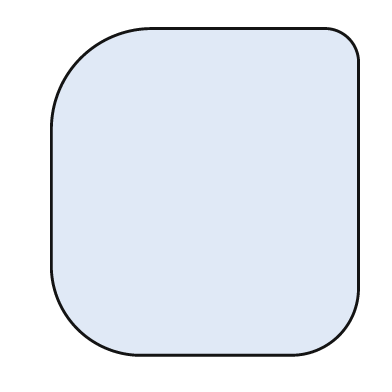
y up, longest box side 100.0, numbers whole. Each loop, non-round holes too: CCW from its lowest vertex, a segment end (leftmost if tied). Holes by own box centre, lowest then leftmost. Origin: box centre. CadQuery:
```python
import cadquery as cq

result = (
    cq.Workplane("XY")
    .moveTo(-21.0, -50.0)
    .lineTo(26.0, -50.0)
    .threePointArc((41.0, -44.0), (47.0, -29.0))
    .lineTo(47.0, 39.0)
    .threePointArc((44.0, 47.0), (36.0, 50.0))
    .lineTo(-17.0, 50.0)
    .threePointArc((-38.0, 41.0), (-47.0, 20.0))
    .lineTo(-47.0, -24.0)
    .threePointArc((-39.0, -42.0), (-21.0, -50.0))
    .close()
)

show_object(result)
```